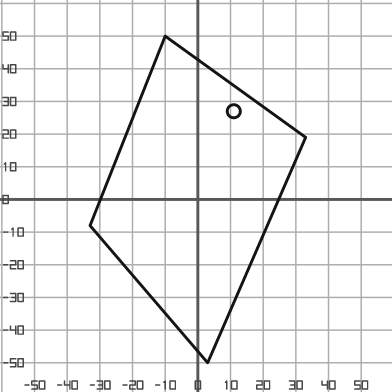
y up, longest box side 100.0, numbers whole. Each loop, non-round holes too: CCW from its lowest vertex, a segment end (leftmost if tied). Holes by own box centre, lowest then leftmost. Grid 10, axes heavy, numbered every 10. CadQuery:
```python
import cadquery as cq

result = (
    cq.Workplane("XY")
    .moveTo(3.0, -50.0)
    .lineTo(33.0, 19.0)
    .lineTo(-10.0, 50.0)
    .lineTo(-33.0, -8.0)
    .close()
    .moveTo(11.0, 27.0)
    .circle(2.0)
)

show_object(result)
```